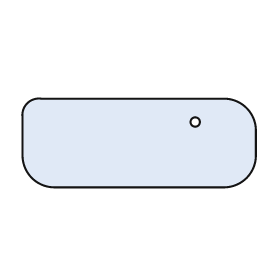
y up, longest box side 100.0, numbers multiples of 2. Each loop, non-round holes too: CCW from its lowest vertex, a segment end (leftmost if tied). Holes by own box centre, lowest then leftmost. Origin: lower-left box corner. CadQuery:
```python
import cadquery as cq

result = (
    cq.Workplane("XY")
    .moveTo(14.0, 0.0)
    .lineTo(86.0, 0.0)
    .threePointArc((96.0, 4.0), (100.0, 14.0))
    .lineTo(100.0, 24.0)
    .threePointArc((96.0, 34.0), (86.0, 38.0))
    .lineTo(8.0, 38.0)
    .threePointArc((2.0, 36.0), (0.0, 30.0))
    .lineTo(0.0, 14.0)
    .threePointArc((4.0, 4.0), (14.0, 0.0))
    .close()
    .moveTo(74.0, 28.0)
    .circle(2.0)
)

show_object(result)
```